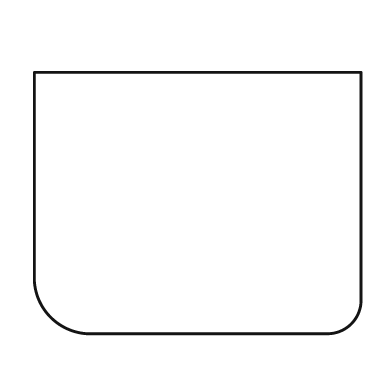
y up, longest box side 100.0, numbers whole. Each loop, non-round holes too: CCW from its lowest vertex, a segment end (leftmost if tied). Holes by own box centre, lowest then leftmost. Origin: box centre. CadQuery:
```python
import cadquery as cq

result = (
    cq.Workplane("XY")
    .moveTo(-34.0, -40.0)
    .lineTo(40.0, -40.0)
    .threePointArc((47.0, -37.0), (50.0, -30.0))
    .lineTo(50.0, 40.0)
    .lineTo(-50.0, 40.0)
    .lineTo(-50.0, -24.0)
    .threePointArc((-45.0, -35.0), (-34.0, -40.0))
    .close()
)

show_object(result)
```